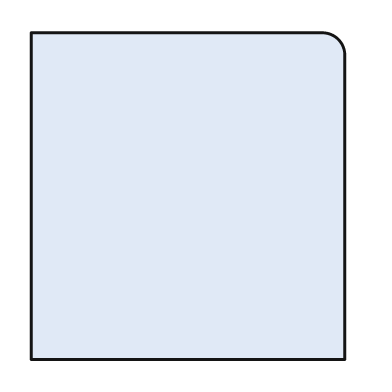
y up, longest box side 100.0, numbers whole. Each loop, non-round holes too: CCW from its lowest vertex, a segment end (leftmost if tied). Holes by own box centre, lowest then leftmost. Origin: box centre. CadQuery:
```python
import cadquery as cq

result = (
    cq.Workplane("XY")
    .moveTo(-48.0, -50.0)
    .lineTo(48.0, -50.0)
    .lineTo(48.0, 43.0)
    .threePointArc((46.0, 48.0), (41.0, 50.0))
    .lineTo(-48.0, 50.0)
    .close()
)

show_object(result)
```